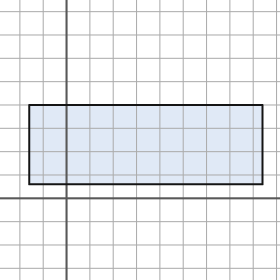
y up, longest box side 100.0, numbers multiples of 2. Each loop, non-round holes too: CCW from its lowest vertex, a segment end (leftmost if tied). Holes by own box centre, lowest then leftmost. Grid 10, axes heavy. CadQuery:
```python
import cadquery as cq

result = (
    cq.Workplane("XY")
    .moveTo(-16.0, 6.0)
    .lineTo(84.0, 6.0)
    .lineTo(84.0, 40.0)
    .lineTo(-16.0, 40.0)
    .close()
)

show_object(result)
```